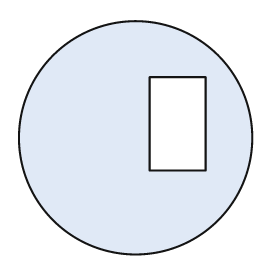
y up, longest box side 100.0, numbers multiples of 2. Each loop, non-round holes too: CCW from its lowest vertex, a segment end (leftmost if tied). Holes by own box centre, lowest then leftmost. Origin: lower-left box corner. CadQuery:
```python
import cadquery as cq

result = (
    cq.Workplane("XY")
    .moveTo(50.0, 50.0)
    .circle(50.0)
    .moveTo(56.0, 36.0)
    .lineTo(80.0, 36.0)
    .lineTo(80.0, 76.0)
    .lineTo(56.0, 76.0)
    .close()
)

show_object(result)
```